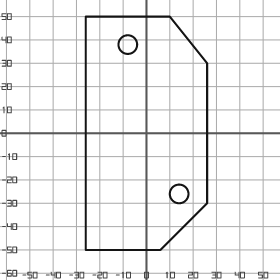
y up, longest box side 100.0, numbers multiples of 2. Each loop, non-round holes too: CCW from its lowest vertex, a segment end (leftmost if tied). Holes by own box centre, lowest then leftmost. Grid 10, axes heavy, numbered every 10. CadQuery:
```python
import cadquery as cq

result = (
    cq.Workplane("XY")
    .moveTo(-26.0, -50.0)
    .lineTo(6.0, -50.0)
    .lineTo(26.0, -30.0)
    .lineTo(26.0, 30.0)
    .lineTo(10.0, 50.0)
    .lineTo(-26.0, 50.0)
    .close()
    .moveTo(14.0, -26.0)
    .circle(4.0)
    .moveTo(-8.0, 38.0)
    .circle(4.0)
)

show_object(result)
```